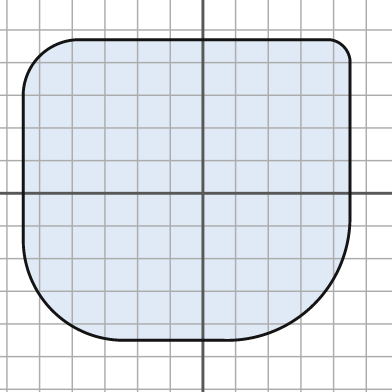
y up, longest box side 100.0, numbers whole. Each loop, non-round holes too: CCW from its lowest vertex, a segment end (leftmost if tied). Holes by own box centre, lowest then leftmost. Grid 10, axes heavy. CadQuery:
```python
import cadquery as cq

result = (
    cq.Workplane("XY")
    .moveTo(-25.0, -45.0)
    .lineTo(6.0, -45.0)
    .threePointArc((34.0, -34.0), (45.0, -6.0))
    .lineTo(45.0, 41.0)
    .threePointArc((43.0, 45.0), (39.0, 47.0))
    .lineTo(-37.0, 47.0)
    .threePointArc((-50.0, 42.0), (-55.0, 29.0))
    .lineTo(-55.0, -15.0)
    .threePointArc((-46.0, -36.0), (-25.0, -45.0))
    .close()
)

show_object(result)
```